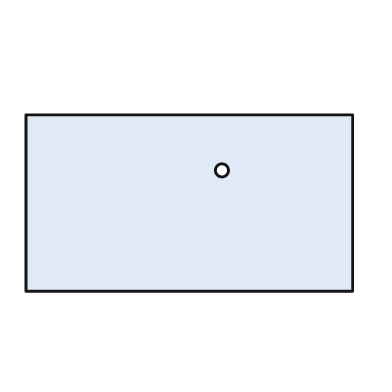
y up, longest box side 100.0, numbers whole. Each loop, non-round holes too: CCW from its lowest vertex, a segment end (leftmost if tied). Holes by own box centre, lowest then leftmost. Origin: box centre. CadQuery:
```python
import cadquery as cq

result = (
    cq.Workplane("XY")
    .moveTo(-50.0, -27.0)
    .lineTo(50.0, -27.0)
    .lineTo(50.0, 27.0)
    .lineTo(-50.0, 27.0)
    .close()
    .moveTo(10.0, 10.0)
    .circle(2.0)
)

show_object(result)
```